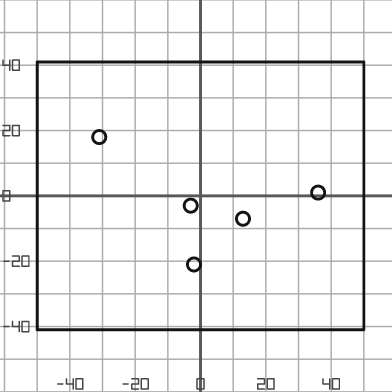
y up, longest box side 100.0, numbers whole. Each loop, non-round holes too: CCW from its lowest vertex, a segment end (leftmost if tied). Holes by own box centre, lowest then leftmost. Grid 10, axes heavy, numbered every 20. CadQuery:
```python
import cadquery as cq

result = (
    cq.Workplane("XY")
    .moveTo(-50.0, -41.0)
    .lineTo(50.0, -41.0)
    .lineTo(50.0, 41.0)
    .lineTo(-50.0, 41.0)
    .close()
    .moveTo(-2.0, -21.0)
    .circle(2.0)
    .moveTo(13.0, -7.0)
    .circle(2.0)
    .moveTo(-3.0, -3.0)
    .circle(2.0)
    .moveTo(36.0, 1.0)
    .circle(2.0)
    .moveTo(-31.0, 18.0)
    .circle(2.0)
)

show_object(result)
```